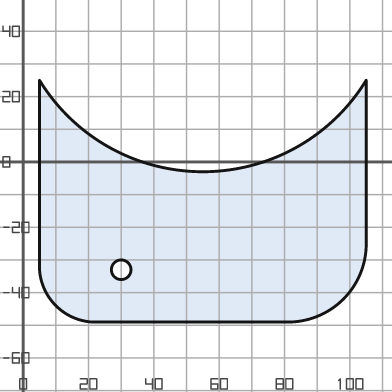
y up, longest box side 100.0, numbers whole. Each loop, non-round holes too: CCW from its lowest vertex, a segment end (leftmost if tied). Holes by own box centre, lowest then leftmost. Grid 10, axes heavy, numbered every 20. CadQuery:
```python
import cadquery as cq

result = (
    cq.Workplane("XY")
    .moveTo(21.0, -49.0)
    .lineTo(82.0, -49.0)
    .threePointArc((98.0, -42.0), (105.0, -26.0))
    .lineTo(105.0, 25.0)
    .threePointArc((55.0, -3.0), (5.0, 25.0))
    .lineTo(5.0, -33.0)
    .threePointArc((10.0, -44.0), (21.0, -49.0))
    .close()
    .moveTo(30.0, -33.0)
    .circle(3.0)
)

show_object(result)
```